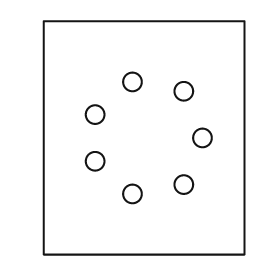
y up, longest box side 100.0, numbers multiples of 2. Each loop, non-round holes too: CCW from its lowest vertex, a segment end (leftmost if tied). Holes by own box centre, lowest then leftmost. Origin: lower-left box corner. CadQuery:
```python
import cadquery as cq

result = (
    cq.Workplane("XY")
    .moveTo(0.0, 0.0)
    .lineTo(86.0, 0.0)
    .lineTo(86.0, 100.0)
    .lineTo(0.0, 100.0)
    .close()
    .moveTo(38.0, 26.0)
    .circle(4.0)
    .moveTo(60.0, 30.0)
    .circle(4.0)
    .moveTo(22.0, 40.0)
    .circle(4.0)
    .moveTo(68.0, 50.0)
    .circle(4.0)
    .moveTo(22.0, 60.0)
    .circle(4.0)
    .moveTo(60.0, 70.0)
    .circle(4.0)
    .moveTo(38.0, 74.0)
    .circle(4.0)
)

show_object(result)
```